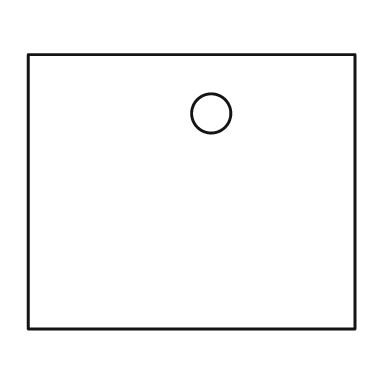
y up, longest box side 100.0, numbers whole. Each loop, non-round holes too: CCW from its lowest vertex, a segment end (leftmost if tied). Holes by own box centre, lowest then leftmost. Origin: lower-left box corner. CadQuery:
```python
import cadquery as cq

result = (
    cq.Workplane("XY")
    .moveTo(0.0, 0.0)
    .lineTo(100.0, 0.0)
    .lineTo(100.0, 84.0)
    .lineTo(0.0, 84.0)
    .close()
    .moveTo(56.0, 66.0)
    .circle(6.0)
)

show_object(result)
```